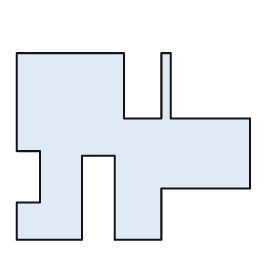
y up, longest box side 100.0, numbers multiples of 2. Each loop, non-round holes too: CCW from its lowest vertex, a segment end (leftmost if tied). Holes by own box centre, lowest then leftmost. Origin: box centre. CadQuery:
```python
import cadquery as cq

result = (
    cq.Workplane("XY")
    .moveTo(-50.0, -40.0)
    .lineTo(-22.0, -40.0)
    .lineTo(-22.0, -4.0)
    .lineTo(-8.0, -4.0)
    .lineTo(-8.0, -40.0)
    .lineTo(12.0, -40.0)
    .lineTo(12.0, -18.0)
    .lineTo(50.0, -18.0)
    .lineTo(50.0, 12.0)
    .lineTo(16.0, 12.0)
    .lineTo(16.0, 40.0)
    .lineTo(12.0, 40.0)
    .lineTo(12.0, 12.0)
    .lineTo(-4.0, 12.0)
    .lineTo(-4.0, 40.0)
    .lineTo(-50.0, 40.0)
    .lineTo(-50.0, -2.0)
    .lineTo(-40.0, -2.0)
    .lineTo(-40.0, -24.0)
    .lineTo(-50.0, -24.0)
    .close()
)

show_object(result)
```